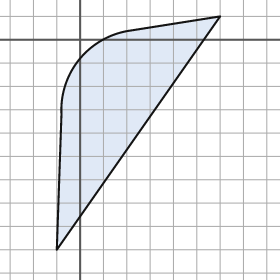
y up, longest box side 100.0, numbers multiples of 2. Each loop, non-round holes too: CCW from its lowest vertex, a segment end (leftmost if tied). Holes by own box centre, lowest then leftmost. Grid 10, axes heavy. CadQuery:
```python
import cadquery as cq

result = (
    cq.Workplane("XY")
    .moveTo(-10.0, -90.0)
    .lineTo(60.0, 10.0)
    .lineTo(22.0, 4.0)
    .threePointArc((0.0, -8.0), (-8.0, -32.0))
    .close()
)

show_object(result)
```